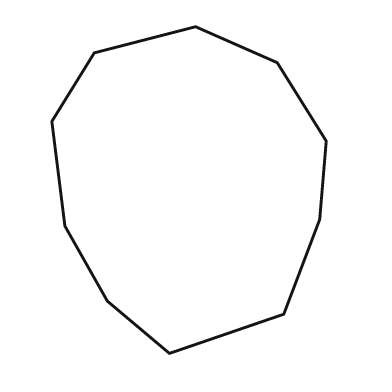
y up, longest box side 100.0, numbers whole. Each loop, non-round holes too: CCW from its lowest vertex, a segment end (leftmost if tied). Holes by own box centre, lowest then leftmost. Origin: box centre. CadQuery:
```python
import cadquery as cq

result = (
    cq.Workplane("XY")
    .moveTo(-6.0, -50.0)
    .lineTo(29.0, -38.0)
    .lineTo(40.0, -9.0)
    .lineTo(42.0, 15.0)
    .lineTo(27.0, 39.0)
    .lineTo(2.0, 50.0)
    .lineTo(-29.0, 42.0)
    .lineTo(-42.0, 21.0)
    .lineTo(-38.0, -11.0)
    .lineTo(-25.0, -34.0)
    .close()
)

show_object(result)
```